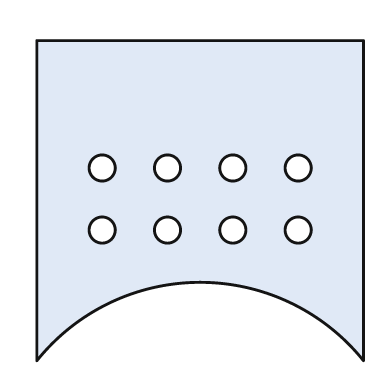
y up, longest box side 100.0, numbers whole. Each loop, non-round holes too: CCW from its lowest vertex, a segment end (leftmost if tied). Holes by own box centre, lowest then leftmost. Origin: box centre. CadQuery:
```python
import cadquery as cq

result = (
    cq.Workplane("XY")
    .moveTo(-50.0, -49.0)
    .threePointArc((0.0, -25.0), (50.0, -49.0))
    .lineTo(50.0, 49.0)
    .lineTo(-50.0, 49.0)
    .close()
    .moveTo(-30.0, -9.0)
    .circle(4.0)
    .moveTo(-10.0, -9.0)
    .circle(4.0)
    .moveTo(10.0, -9.0)
    .circle(4.0)
    .moveTo(30.0, -9.0)
    .circle(4.0)
    .moveTo(-30.0, 10.0)
    .circle(4.0)
    .moveTo(-10.0, 10.0)
    .circle(4.0)
    .moveTo(10.0, 10.0)
    .circle(4.0)
    .moveTo(30.0, 10.0)
    .circle(4.0)
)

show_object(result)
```